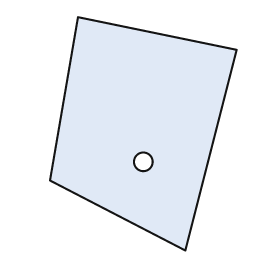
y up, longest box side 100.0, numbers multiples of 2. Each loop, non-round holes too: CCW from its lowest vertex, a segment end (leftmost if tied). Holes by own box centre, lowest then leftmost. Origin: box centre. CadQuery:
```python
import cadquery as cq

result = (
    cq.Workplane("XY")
    .moveTo(18.0, -50.0)
    .lineTo(40.0, 36.0)
    .lineTo(-28.0, 50.0)
    .lineTo(-40.0, -20.0)
    .close()
    .moveTo(0.0, -12.0)
    .circle(4.0)
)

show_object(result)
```